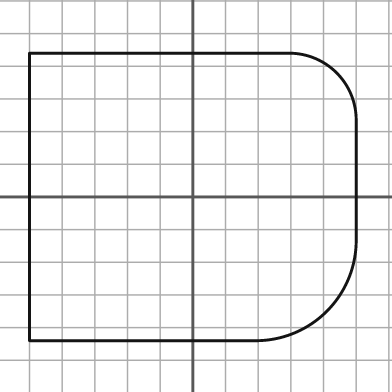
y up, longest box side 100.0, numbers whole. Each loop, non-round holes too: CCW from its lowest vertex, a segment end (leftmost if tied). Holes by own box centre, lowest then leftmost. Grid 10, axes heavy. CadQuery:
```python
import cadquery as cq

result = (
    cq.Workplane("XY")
    .moveTo(-50.0, -44.0)
    .lineTo(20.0, -44.0)
    .threePointArc((41.0, -35.0), (50.0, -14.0))
    .lineTo(50.0, 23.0)
    .threePointArc((44.0, 38.0), (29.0, 44.0))
    .lineTo(-50.0, 44.0)
    .close()
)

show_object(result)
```